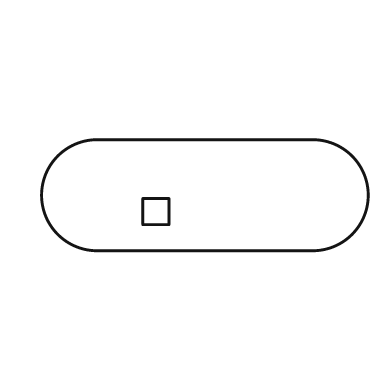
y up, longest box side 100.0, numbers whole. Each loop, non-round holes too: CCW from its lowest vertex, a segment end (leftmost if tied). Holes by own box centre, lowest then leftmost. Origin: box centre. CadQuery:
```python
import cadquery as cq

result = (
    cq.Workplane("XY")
    .moveTo(-33.0, -17.0)
    .lineTo(33.0, -17.0)
    .threePointArc((50.0, 0.0), (33.0, 17.0))
    .lineTo(-33.0, 17.0)
    .threePointArc((-50.0, 0.0), (-33.0, -17.0))
    .close()
    .moveTo(-19.0, -9.0)
    .lineTo(-11.0, -9.0)
    .lineTo(-11.0, -1.0)
    .lineTo(-19.0, -1.0)
    .close()
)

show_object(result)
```